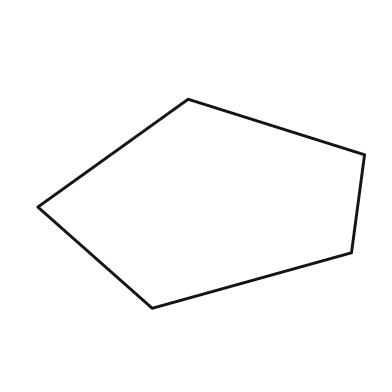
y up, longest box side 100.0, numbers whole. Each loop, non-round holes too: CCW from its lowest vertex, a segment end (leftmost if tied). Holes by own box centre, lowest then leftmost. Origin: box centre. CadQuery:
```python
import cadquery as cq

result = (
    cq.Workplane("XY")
    .moveTo(-15.0, -32.0)
    .lineTo(46.0, -15.0)
    .lineTo(50.0, 15.0)
    .lineTo(-4.0, 32.0)
    .lineTo(-50.0, -1.0)
    .close()
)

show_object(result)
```